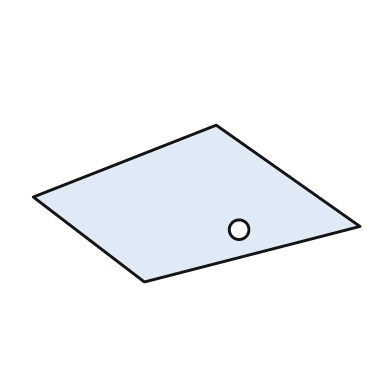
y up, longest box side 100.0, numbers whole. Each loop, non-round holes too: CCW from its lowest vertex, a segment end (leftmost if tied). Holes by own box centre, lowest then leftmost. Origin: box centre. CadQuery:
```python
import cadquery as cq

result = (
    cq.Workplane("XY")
    .moveTo(-16.0, -24.0)
    .lineTo(50.0, -7.0)
    .lineTo(6.0, 24.0)
    .lineTo(-50.0, 2.0)
    .close()
    .moveTo(13.0, -8.0)
    .circle(3.0)
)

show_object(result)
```